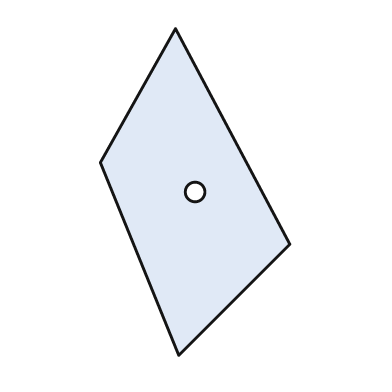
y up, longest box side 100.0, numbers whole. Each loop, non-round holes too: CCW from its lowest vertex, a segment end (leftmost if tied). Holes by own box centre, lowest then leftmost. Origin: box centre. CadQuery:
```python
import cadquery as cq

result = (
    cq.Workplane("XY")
    .moveTo(-5.0, -50.0)
    .lineTo(29.0, -16.0)
    .lineTo(-6.0, 50.0)
    .lineTo(-29.0, 9.0)
    .close()
    .moveTo(0.0, 0.0)
    .circle(3.0)
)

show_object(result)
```